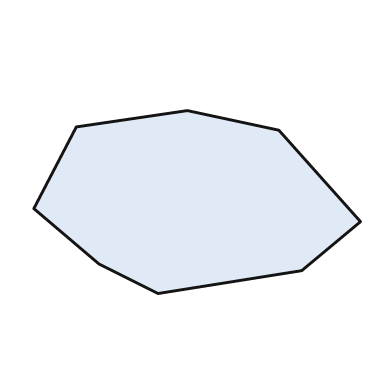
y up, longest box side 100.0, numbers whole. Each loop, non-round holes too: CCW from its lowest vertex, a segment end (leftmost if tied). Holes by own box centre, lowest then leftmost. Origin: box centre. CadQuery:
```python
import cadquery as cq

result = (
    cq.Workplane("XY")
    .moveTo(-12.0, -28.0)
    .lineTo(32.0, -21.0)
    .lineTo(50.0, -6.0)
    .lineTo(25.0, 22.0)
    .lineTo(-3.0, 28.0)
    .lineTo(-37.0, 23.0)
    .lineTo(-50.0, -2.0)
    .lineTo(-30.0, -19.0)
    .close()
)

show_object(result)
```